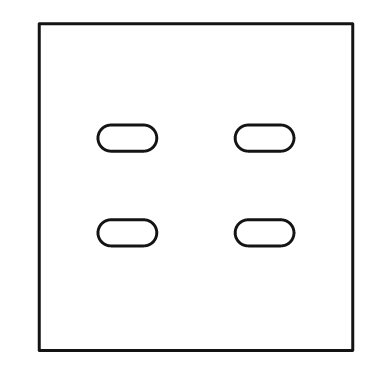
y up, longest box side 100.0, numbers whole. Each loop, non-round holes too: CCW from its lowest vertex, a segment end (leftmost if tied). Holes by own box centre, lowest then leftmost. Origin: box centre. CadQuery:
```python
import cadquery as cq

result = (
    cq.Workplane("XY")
    .moveTo(-48.0, -50.0)
    .lineTo(48.0, -50.0)
    .lineTo(48.0, 50.0)
    .lineTo(-48.0, 50.0)
    .close()
    .moveTo(-26.0, -18.0)
    .lineTo(-16.0, -18.0)
    .threePointArc((-12.0, -14.0), (-16.0, -10.0))
    .lineTo(-26.0, -10.0)
    .threePointArc((-30.0, -14.0), (-26.0, -18.0))
    .close()
    .moveTo(16.0, -18.0)
    .lineTo(26.0, -18.0)
    .threePointArc((30.0, -14.0), (26.0, -10.0))
    .lineTo(16.0, -10.0)
    .threePointArc((12.0, -14.0), (16.0, -18.0))
    .close()
    .moveTo(-26.0, 11.0)
    .lineTo(-16.0, 11.0)
    .threePointArc((-12.0, 15.0), (-16.0, 19.0))
    .lineTo(-26.0, 19.0)
    .threePointArc((-30.0, 15.0), (-26.0, 11.0))
    .close()
    .moveTo(16.0, 11.0)
    .lineTo(26.0, 11.0)
    .threePointArc((30.0, 15.0), (26.0, 19.0))
    .lineTo(16.0, 19.0)
    .threePointArc((12.0, 15.0), (16.0, 11.0))
    .close()
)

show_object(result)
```